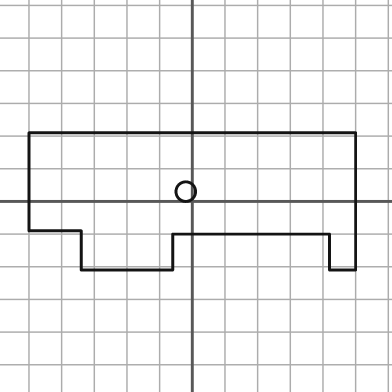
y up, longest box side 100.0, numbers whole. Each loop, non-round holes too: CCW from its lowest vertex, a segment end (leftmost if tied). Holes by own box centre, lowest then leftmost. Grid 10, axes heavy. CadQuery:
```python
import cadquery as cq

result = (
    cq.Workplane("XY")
    .moveTo(-34.0, -21.0)
    .lineTo(-6.0, -21.0)
    .lineTo(-6.0, -10.0)
    .lineTo(42.0, -10.0)
    .lineTo(42.0, -21.0)
    .lineTo(50.0, -21.0)
    .lineTo(50.0, 21.0)
    .lineTo(-50.0, 21.0)
    .lineTo(-50.0, -9.0)
    .lineTo(-34.0, -9.0)
    .close()
    .moveTo(-2.0, 3.0)
    .circle(3.0)
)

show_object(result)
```